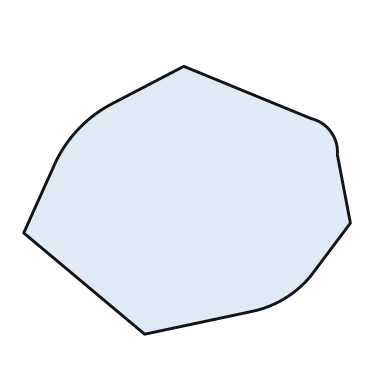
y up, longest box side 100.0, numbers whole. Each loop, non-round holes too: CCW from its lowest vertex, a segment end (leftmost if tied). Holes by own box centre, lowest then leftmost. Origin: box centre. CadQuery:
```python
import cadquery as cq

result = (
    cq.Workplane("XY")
    .moveTo(-13.0, -41.0)
    .lineTo(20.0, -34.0)
    .threePointArc((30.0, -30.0), (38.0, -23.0))
    .lineTo(50.0, -7.0)
    .lineTo(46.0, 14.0)
    .threePointArc((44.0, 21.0), (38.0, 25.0))
    .lineTo(-1.0, 41.0)
    .lineTo(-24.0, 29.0)
    .threePointArc((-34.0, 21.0), (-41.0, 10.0))
    .lineTo(-50.0, -10.0)
    .close()
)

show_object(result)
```